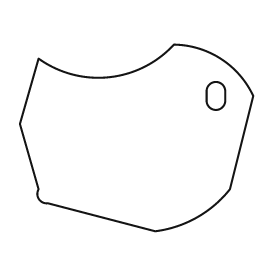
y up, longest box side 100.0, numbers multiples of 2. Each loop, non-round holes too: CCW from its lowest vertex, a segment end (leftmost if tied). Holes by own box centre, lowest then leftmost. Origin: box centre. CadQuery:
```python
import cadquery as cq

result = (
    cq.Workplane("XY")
    .moveTo(8.0, -40.0)
    .threePointArc((26.0, -34.0), (40.0, -22.0))
    .lineTo(50.0, 18.0)
    .threePointArc((36.0, 34.0), (16.0, 40.0))
    .threePointArc((-12.0, 26.0), (-42.0, 34.0))
    .lineTo(-50.0, 6.0)
    .lineTo(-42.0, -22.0)
    .threePointArc((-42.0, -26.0), (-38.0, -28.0))
    .close()
    .moveTo(30.0, 16.0)
    .threePointArc((34.0, 12.0), (38.0, 16.0))
    .lineTo(38.0, 20.0)
    .threePointArc((34.0, 24.0), (30.0, 20.0))
    .close()
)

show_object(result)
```